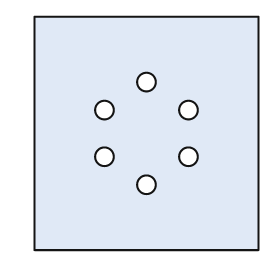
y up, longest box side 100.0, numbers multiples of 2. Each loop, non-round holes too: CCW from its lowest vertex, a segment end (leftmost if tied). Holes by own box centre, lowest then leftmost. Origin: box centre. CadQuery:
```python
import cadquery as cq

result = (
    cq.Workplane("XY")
    .moveTo(-48.0, -50.0)
    .lineTo(48.0, -50.0)
    .lineTo(48.0, 50.0)
    .lineTo(-48.0, 50.0)
    .close()
    .moveTo(0.0, -22.0)
    .circle(4.0)
    .moveTo(-18.0, -10.0)
    .circle(4.0)
    .moveTo(18.0, -10.0)
    .circle(4.0)
    .moveTo(-18.0, 10.0)
    .circle(4.0)
    .moveTo(18.0, 10.0)
    .circle(4.0)
    .moveTo(0.0, 22.0)
    .circle(4.0)
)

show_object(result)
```